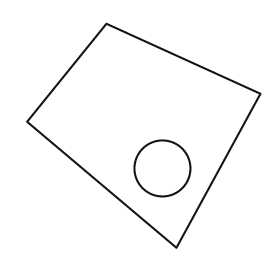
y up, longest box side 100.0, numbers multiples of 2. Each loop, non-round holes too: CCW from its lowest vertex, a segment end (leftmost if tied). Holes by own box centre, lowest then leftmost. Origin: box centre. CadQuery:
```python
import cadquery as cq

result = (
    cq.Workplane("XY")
    .moveTo(14.0, -48.0)
    .lineTo(50.0, 18.0)
    .lineTo(-16.0, 48.0)
    .lineTo(-50.0, 6.0)
    .close()
    .moveTo(8.0, -14.0)
    .circle(12.0)
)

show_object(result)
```